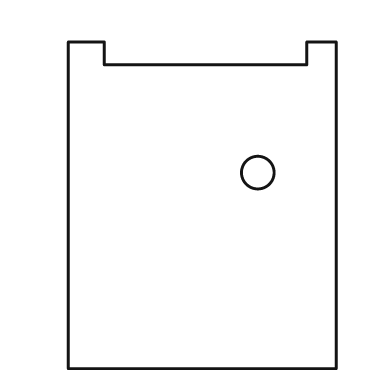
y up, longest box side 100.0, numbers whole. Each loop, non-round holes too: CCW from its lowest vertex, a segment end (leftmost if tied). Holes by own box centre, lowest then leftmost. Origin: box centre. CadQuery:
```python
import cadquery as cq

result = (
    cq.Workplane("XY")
    .moveTo(-41.0, -50.0)
    .lineTo(41.0, -50.0)
    .lineTo(41.0, 50.0)
    .lineTo(32.0, 50.0)
    .lineTo(32.0, 43.0)
    .lineTo(-30.0, 43.0)
    .lineTo(-30.0, 50.0)
    .lineTo(-41.0, 50.0)
    .close()
    .moveTo(17.0, 10.0)
    .circle(5.0)
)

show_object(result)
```